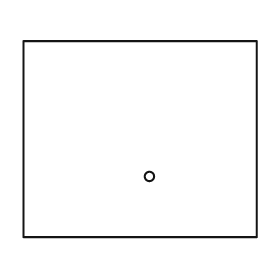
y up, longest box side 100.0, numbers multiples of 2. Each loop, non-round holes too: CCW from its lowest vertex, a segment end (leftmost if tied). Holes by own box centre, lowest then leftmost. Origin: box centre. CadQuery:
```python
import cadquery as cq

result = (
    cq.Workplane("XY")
    .moveTo(-50.0, -42.0)
    .lineTo(50.0, -42.0)
    .lineTo(50.0, 42.0)
    .lineTo(-50.0, 42.0)
    .close()
    .moveTo(4.0, -16.0)
    .circle(2.0)
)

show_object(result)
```